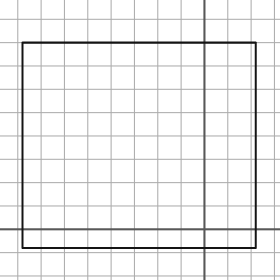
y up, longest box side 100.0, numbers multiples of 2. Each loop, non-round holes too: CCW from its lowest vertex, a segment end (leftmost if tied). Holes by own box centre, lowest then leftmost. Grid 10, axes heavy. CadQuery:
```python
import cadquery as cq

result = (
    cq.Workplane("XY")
    .moveTo(-78.0, -8.0)
    .lineTo(22.0, -8.0)
    .lineTo(22.0, 80.0)
    .lineTo(-78.0, 80.0)
    .close()
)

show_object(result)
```